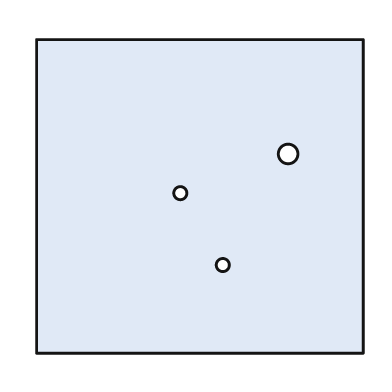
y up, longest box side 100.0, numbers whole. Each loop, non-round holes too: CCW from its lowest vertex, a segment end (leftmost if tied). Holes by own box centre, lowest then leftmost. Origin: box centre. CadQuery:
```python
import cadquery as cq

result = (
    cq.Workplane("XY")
    .moveTo(-50.0, -48.0)
    .lineTo(50.0, -48.0)
    .lineTo(50.0, 48.0)
    .lineTo(-50.0, 48.0)
    .close()
    .moveTo(7.0, -21.0)
    .circle(2.0)
    .moveTo(-6.0, 1.0)
    .circle(2.0)
    .moveTo(27.0, 13.0)
    .circle(3.0)
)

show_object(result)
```